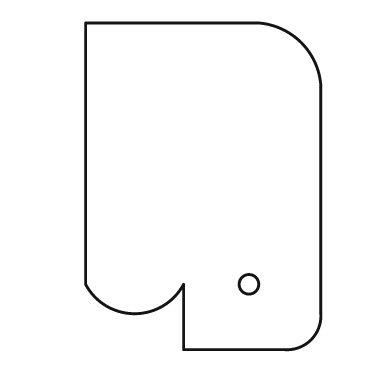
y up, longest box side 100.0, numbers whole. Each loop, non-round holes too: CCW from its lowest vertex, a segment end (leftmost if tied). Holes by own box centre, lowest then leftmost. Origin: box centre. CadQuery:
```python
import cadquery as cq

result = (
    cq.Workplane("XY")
    .moveTo(-6.0, -50.0)
    .lineTo(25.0, -50.0)
    .threePointArc((33.0, -47.0), (36.0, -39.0))
    .lineTo(36.0, 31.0)
    .threePointArc((30.0, 44.0), (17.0, 50.0))
    .lineTo(-36.0, 50.0)
    .lineTo(-36.0, -30.0)
    .threePointArc((-21.0, -39.0), (-6.0, -30.0))
    .close()
    .moveTo(14.0, -30.0)
    .circle(3.0)
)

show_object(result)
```